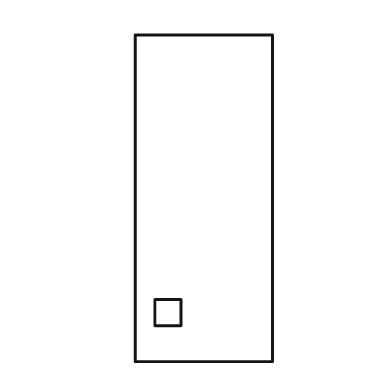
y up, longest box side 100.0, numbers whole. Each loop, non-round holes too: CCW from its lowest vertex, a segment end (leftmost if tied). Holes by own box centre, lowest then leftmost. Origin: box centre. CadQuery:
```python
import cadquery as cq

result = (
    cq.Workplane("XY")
    .moveTo(-21.0, -50.0)
    .lineTo(21.0, -50.0)
    .lineTo(21.0, 50.0)
    .lineTo(-21.0, 50.0)
    .close()
    .moveTo(-15.0, -39.0)
    .lineTo(-7.0, -39.0)
    .lineTo(-7.0, -31.0)
    .lineTo(-15.0, -31.0)
    .close()
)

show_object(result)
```